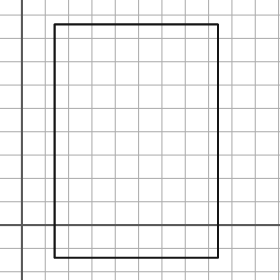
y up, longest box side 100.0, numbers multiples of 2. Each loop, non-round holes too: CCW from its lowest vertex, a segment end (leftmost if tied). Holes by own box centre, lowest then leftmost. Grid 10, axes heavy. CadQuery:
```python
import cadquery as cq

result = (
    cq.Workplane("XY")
    .moveTo(14.0, -14.0)
    .lineTo(84.0, -14.0)
    .lineTo(84.0, 86.0)
    .lineTo(14.0, 86.0)
    .close()
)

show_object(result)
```